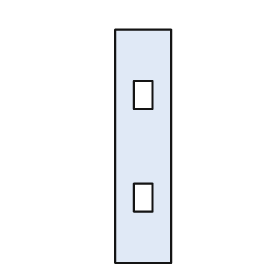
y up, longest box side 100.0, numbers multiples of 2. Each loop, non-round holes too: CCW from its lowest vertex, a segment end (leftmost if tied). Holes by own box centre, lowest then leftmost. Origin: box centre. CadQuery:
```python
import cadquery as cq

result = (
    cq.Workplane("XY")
    .moveTo(-12.0, -50.0)
    .lineTo(12.0, -50.0)
    .lineTo(12.0, 50.0)
    .lineTo(-12.0, 50.0)
    .close()
    .moveTo(-4.0, -28.0)
    .lineTo(4.0, -28.0)
    .lineTo(4.0, -16.0)
    .lineTo(-4.0, -16.0)
    .close()
    .moveTo(-4.0, 16.0)
    .lineTo(4.0, 16.0)
    .lineTo(4.0, 28.0)
    .lineTo(-4.0, 28.0)
    .close()
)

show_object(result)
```